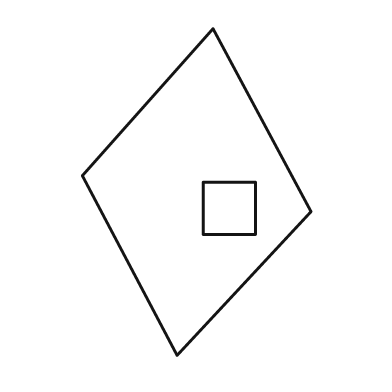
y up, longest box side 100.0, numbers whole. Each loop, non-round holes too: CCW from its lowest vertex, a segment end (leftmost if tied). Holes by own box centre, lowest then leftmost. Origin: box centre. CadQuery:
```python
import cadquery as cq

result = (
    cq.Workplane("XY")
    .moveTo(-6.0, -50.0)
    .lineTo(35.0, -6.0)
    .lineTo(5.0, 50.0)
    .lineTo(-35.0, 5.0)
    .close()
    .moveTo(2.0, -13.0)
    .lineTo(18.0, -13.0)
    .lineTo(18.0, 3.0)
    .lineTo(2.0, 3.0)
    .close()
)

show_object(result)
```